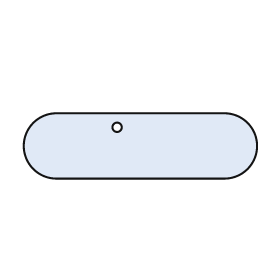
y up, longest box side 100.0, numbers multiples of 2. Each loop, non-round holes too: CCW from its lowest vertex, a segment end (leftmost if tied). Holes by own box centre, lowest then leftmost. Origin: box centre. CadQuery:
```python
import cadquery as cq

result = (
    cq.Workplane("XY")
    .moveTo(-36.0, -14.0)
    .lineTo(36.0, -14.0)
    .threePointArc((50.0, 0.0), (36.0, 14.0))
    .lineTo(-36.0, 14.0)
    .threePointArc((-50.0, 0.0), (-36.0, -14.0))
    .close()
    .moveTo(-10.0, 8.0)
    .circle(2.0)
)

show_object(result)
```